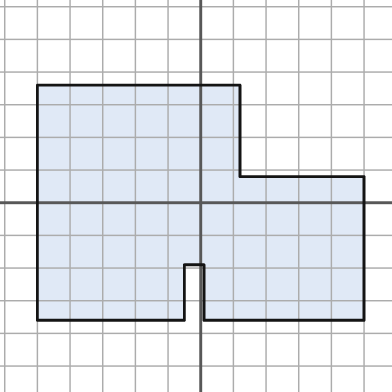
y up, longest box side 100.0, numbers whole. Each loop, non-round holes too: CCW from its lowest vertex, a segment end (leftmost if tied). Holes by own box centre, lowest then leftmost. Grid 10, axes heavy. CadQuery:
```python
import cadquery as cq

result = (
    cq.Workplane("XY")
    .moveTo(-50.0, -36.0)
    .lineTo(-5.0, -36.0)
    .lineTo(-5.0, -19.0)
    .lineTo(1.0, -19.0)
    .lineTo(1.0, -36.0)
    .lineTo(50.0, -36.0)
    .lineTo(50.0, 8.0)
    .lineTo(12.0, 8.0)
    .lineTo(12.0, 36.0)
    .lineTo(-50.0, 36.0)
    .close()
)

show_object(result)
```